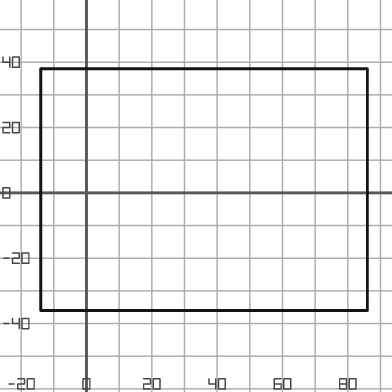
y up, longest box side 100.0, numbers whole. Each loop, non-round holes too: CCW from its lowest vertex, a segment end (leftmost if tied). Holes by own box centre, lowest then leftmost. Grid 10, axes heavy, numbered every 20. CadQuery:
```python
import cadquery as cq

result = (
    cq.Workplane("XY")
    .moveTo(-14.0, -36.0)
    .lineTo(86.0, -36.0)
    .lineTo(86.0, 38.0)
    .lineTo(-14.0, 38.0)
    .close()
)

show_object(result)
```